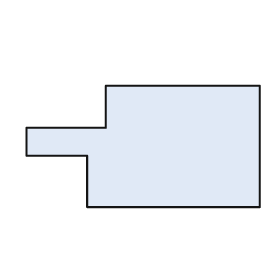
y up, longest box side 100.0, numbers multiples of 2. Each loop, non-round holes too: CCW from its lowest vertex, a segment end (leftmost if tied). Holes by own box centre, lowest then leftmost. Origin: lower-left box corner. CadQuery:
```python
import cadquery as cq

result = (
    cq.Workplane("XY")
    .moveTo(26.0, 0.0)
    .lineTo(100.0, 0.0)
    .lineTo(100.0, 52.0)
    .lineTo(34.0, 52.0)
    .lineTo(34.0, 34.0)
    .lineTo(0.0, 34.0)
    .lineTo(0.0, 22.0)
    .lineTo(26.0, 22.0)
    .close()
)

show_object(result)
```